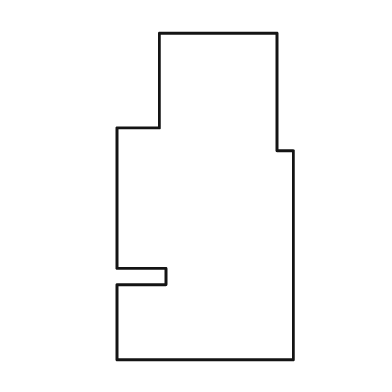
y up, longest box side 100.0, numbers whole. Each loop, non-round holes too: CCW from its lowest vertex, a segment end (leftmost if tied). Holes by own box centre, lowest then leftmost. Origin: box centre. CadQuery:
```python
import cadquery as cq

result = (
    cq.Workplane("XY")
    .moveTo(-27.0, -50.0)
    .lineTo(27.0, -50.0)
    .lineTo(27.0, 14.0)
    .lineTo(22.0, 14.0)
    .lineTo(22.0, 50.0)
    .lineTo(-14.0, 50.0)
    .lineTo(-14.0, 21.0)
    .lineTo(-27.0, 21.0)
    .lineTo(-27.0, -22.0)
    .lineTo(-12.0, -22.0)
    .lineTo(-12.0, -27.0)
    .lineTo(-27.0, -27.0)
    .close()
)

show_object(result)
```